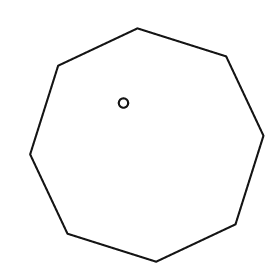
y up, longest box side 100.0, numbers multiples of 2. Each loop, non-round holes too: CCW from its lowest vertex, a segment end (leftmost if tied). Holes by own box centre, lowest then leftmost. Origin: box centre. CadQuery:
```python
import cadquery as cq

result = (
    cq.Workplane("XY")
    .moveTo(4.0, -50.0)
    .lineTo(38.0, -34.0)
    .lineTo(50.0, 4.0)
    .lineTo(34.0, 38.0)
    .lineTo(-4.0, 50.0)
    .lineTo(-38.0, 34.0)
    .lineTo(-50.0, -4.0)
    .lineTo(-34.0, -38.0)
    .close()
    .moveTo(-10.0, 18.0)
    .circle(2.0)
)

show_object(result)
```